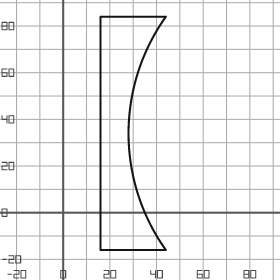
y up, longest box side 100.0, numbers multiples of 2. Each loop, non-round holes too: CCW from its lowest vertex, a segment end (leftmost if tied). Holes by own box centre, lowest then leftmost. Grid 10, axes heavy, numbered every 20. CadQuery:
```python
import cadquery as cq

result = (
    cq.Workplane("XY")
    .moveTo(16.0, -16.0)
    .lineTo(44.0, -16.0)
    .threePointArc((28.0, 34.0), (44.0, 84.0))
    .lineTo(16.0, 84.0)
    .close()
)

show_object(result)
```